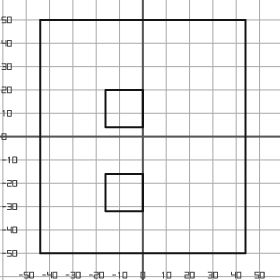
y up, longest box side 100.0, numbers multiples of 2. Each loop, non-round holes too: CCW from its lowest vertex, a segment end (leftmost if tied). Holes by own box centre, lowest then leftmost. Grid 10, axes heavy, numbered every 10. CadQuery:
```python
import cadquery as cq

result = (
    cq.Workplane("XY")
    .moveTo(-44.0, -50.0)
    .lineTo(44.0, -50.0)
    .lineTo(44.0, 50.0)
    .lineTo(-44.0, 50.0)
    .close()
    .moveTo(-16.0, -32.0)
    .lineTo(0.0, -32.0)
    .lineTo(0.0, -16.0)
    .lineTo(-16.0, -16.0)
    .close()
    .moveTo(-16.0, 4.0)
    .lineTo(0.0, 4.0)
    .lineTo(0.0, 20.0)
    .lineTo(-16.0, 20.0)
    .close()
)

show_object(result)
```